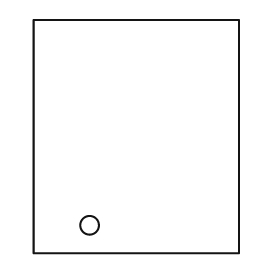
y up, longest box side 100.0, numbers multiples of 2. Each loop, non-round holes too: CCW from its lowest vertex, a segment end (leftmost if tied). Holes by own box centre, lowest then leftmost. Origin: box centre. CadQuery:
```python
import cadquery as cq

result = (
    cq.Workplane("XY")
    .moveTo(-44.0, -50.0)
    .lineTo(44.0, -50.0)
    .lineTo(44.0, 50.0)
    .lineTo(-44.0, 50.0)
    .close()
    .moveTo(-20.0, -38.0)
    .circle(4.0)
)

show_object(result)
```